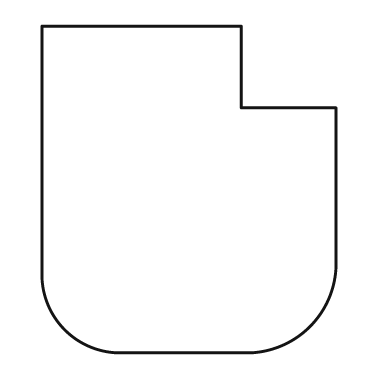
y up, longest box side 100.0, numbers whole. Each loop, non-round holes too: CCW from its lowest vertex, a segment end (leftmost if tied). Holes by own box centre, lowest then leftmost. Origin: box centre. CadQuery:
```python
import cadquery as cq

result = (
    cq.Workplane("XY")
    .moveTo(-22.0, -50.0)
    .lineTo(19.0, -50.0)
    .threePointArc((37.0, -42.0), (45.0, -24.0))
    .lineTo(45.0, 25.0)
    .lineTo(16.0, 25.0)
    .lineTo(16.0, 50.0)
    .lineTo(-45.0, 50.0)
    .lineTo(-45.0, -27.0)
    .threePointArc((-38.0, -43.0), (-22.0, -50.0))
    .close()
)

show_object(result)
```